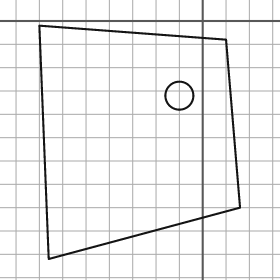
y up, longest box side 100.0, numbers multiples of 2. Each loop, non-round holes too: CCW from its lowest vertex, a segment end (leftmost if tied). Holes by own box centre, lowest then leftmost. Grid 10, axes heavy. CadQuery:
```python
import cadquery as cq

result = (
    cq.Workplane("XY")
    .moveTo(-66.0, -102.0)
    .lineTo(16.0, -80.0)
    .lineTo(10.0, -8.0)
    .lineTo(-70.0, -2.0)
    .close()
    .moveTo(-10.0, -32.0)
    .circle(6.0)
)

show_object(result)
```